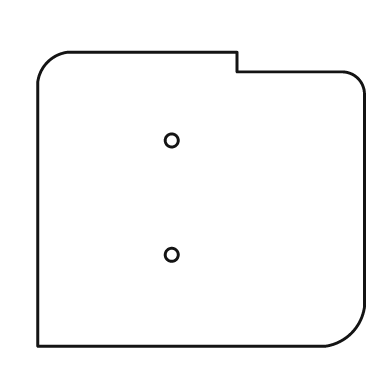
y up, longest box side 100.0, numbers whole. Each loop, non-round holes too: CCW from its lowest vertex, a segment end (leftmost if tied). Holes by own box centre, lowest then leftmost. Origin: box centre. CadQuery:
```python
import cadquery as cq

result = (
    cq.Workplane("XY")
    .moveTo(-50.0, -45.0)
    .lineTo(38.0, -45.0)
    .threePointArc((46.0, -41.0), (50.0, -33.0))
    .lineTo(50.0, 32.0)
    .threePointArc((48.0, 37.0), (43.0, 39.0))
    .lineTo(11.0, 39.0)
    .lineTo(11.0, 45.0)
    .lineTo(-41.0, 45.0)
    .threePointArc((-47.0, 42.0), (-50.0, 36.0))
    .close()
    .moveTo(-9.0, -17.0)
    .circle(2.0)
    .moveTo(-9.0, 18.0)
    .circle(2.0)
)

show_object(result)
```